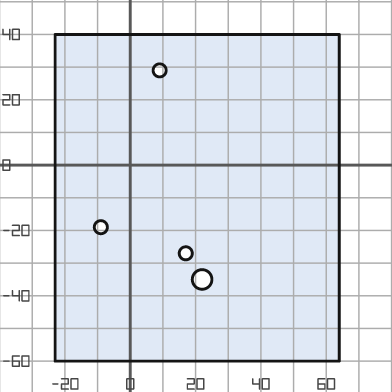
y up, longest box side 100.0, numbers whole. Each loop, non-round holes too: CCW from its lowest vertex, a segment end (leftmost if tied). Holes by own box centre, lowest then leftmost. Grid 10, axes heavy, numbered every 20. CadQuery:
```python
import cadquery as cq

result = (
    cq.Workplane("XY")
    .moveTo(-23.0, -60.0)
    .lineTo(64.0, -60.0)
    .lineTo(64.0, 40.0)
    .lineTo(-23.0, 40.0)
    .close()
    .moveTo(22.0, -35.0)
    .circle(3.0)
    .moveTo(17.0, -27.0)
    .circle(2.0)
    .moveTo(-9.0, -19.0)
    .circle(2.0)
    .moveTo(9.0, 29.0)
    .circle(2.0)
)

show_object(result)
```